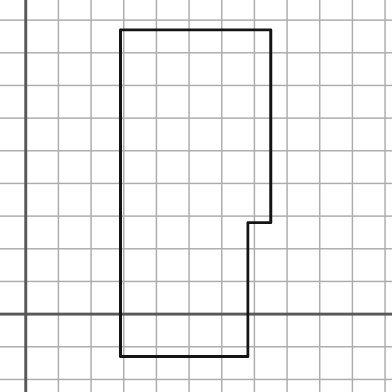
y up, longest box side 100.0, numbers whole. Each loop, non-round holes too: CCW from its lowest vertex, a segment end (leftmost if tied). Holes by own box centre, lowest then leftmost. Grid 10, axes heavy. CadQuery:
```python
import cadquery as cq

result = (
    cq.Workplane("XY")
    .moveTo(29.0, -13.0)
    .lineTo(68.0, -13.0)
    .lineTo(68.0, 28.0)
    .lineTo(75.0, 28.0)
    .lineTo(75.0, 87.0)
    .lineTo(29.0, 87.0)
    .close()
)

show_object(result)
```